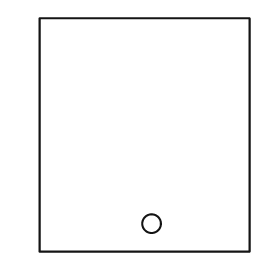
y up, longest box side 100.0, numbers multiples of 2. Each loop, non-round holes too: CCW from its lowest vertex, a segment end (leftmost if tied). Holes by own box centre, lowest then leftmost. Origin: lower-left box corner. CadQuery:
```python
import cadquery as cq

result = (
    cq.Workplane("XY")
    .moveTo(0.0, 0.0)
    .lineTo(90.0, 0.0)
    .lineTo(90.0, 100.0)
    .lineTo(0.0, 100.0)
    .close()
    .moveTo(48.0, 12.0)
    .circle(4.0)
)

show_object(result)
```